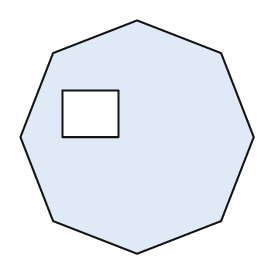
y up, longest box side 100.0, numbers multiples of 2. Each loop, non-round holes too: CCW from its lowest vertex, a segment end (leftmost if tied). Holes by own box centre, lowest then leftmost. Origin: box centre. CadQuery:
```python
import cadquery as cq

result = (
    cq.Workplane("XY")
    .moveTo(0.0, -50.0)
    .lineTo(36.0, -36.0)
    .lineTo(50.0, 0.0)
    .lineTo(36.0, 36.0)
    .lineTo(0.0, 50.0)
    .lineTo(-36.0, 36.0)
    .lineTo(-50.0, 0.0)
    .lineTo(-36.0, -36.0)
    .close()
    .moveTo(-32.0, 0.0)
    .lineTo(-8.0, 0.0)
    .lineTo(-8.0, 20.0)
    .lineTo(-32.0, 20.0)
    .close()
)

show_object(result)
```